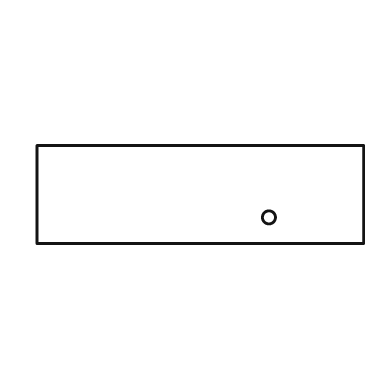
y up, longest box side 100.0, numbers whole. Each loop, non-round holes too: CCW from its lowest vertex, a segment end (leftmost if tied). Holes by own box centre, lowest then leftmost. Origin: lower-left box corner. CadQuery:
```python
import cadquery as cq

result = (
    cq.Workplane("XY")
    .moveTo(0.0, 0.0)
    .lineTo(100.0, 0.0)
    .lineTo(100.0, 30.0)
    .lineTo(0.0, 30.0)
    .close()
    .moveTo(71.0, 8.0)
    .circle(2.0)
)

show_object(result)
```